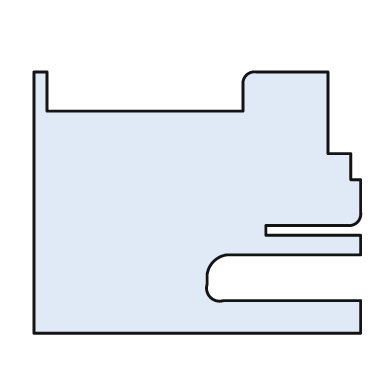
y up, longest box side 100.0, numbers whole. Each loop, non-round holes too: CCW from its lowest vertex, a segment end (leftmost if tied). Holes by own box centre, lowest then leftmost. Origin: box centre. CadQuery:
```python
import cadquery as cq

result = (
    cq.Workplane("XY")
    .moveTo(-50.0, -40.0)
    .lineTo(50.0, -40.0)
    .lineTo(50.0, -30.0)
    .lineTo(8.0, -30.0)
    .threePointArc((4.0, -29.0), (3.0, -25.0))
    .lineTo(3.0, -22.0)
    .threePointArc((5.0, -18.0), (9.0, -16.0))
    .lineTo(50.0, -16.0)
    .lineTo(50.0, -10.0)
    .lineTo(21.0, -10.0)
    .lineTo(21.0, -7.0)
    .lineTo(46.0, -7.0)
    .threePointArc((49.0, -6.0), (50.0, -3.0))
    .lineTo(50.0, 7.0)
    .lineTo(47.0, 7.0)
    .lineTo(47.0, 15.0)
    .lineTo(40.0, 15.0)
    .lineTo(40.0, 40.0)
    .lineTo(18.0, 40.0)
    .threePointArc((15.0, 39.0), (14.0, 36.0))
    .lineTo(14.0, 28.0)
    .lineTo(-46.0, 28.0)
    .lineTo(-46.0, 40.0)
    .lineTo(-50.0, 40.0)
    .close()
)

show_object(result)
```